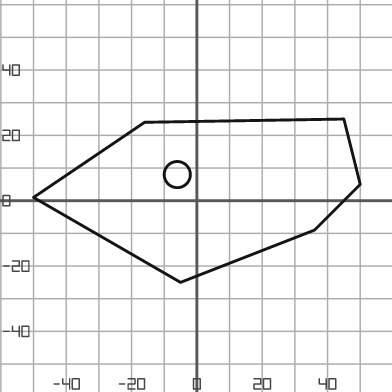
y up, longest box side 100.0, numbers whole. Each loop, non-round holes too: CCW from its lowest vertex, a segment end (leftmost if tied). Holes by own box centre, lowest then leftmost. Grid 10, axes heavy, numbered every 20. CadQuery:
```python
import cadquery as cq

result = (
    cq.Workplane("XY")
    .moveTo(-5.0, -25.0)
    .lineTo(36.0, -9.0)
    .lineTo(50.0, 5.0)
    .lineTo(45.0, 25.0)
    .lineTo(-16.0, 24.0)
    .lineTo(-50.0, 1.0)
    .close()
    .moveTo(-6.0, 8.0)
    .circle(4.0)
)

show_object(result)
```